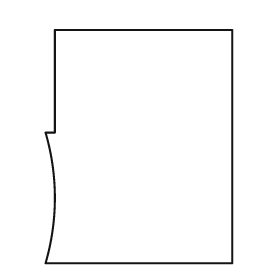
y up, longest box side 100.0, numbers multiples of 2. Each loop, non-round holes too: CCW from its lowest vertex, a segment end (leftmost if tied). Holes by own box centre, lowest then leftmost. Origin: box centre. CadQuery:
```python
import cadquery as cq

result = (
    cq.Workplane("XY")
    .moveTo(-40.0, -50.0)
    .lineTo(40.0, -50.0)
    .lineTo(40.0, 50.0)
    .lineTo(-36.0, 50.0)
    .lineTo(-36.0, 6.0)
    .lineTo(-40.0, 6.0)
    .threePointArc((-36.0, -22.0), (-40.0, -50.0))
    .close()
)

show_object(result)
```